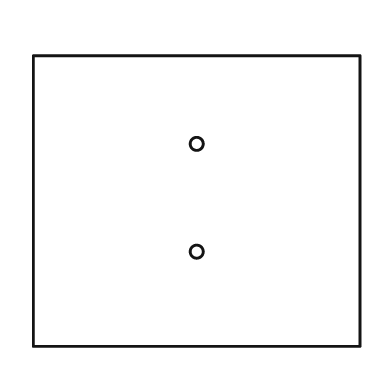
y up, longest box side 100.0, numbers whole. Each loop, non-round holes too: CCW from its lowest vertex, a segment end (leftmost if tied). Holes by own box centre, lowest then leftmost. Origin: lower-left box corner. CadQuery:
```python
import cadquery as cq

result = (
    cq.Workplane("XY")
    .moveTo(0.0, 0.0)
    .lineTo(100.0, 0.0)
    .lineTo(100.0, 89.0)
    .lineTo(0.0, 89.0)
    .close()
    .moveTo(50.0, 29.0)
    .circle(2.0)
    .moveTo(50.0, 62.0)
    .circle(2.0)
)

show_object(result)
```